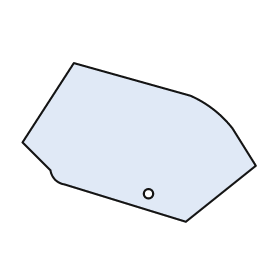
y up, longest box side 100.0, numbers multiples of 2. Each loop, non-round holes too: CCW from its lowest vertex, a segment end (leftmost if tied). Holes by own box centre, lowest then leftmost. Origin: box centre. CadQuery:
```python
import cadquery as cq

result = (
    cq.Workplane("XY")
    .moveTo(20.0, -34.0)
    .lineTo(50.0, -10.0)
    .lineTo(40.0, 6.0)
    .threePointArc((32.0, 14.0), (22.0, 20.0))
    .lineTo(-28.0, 34.0)
    .lineTo(-50.0, 0.0)
    .lineTo(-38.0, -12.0)
    .threePointArc((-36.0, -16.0), (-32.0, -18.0))
    .close()
    .moveTo(4.0, -22.0)
    .circle(2.0)
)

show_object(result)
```